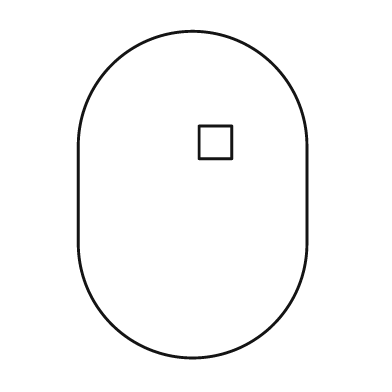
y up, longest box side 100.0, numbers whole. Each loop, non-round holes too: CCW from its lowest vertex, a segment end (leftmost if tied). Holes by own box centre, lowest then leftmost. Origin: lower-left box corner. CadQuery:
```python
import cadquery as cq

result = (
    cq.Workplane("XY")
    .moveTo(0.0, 35.0)
    .threePointArc((35.0, 0.0), (70.0, 35.0))
    .lineTo(70.0, 65.0)
    .threePointArc((35.0, 100.0), (0.0, 65.0))
    .close()
    .moveTo(37.0, 61.0)
    .lineTo(47.0, 61.0)
    .lineTo(47.0, 71.0)
    .lineTo(37.0, 71.0)
    .close()
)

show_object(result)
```